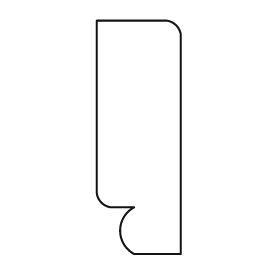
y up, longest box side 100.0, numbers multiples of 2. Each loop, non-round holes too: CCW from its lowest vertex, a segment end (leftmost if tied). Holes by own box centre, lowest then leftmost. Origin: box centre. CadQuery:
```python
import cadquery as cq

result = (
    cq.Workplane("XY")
    .moveTo(-2.0, -50.0)
    .lineTo(18.0, -50.0)
    .lineTo(18.0, 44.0)
    .threePointArc((16.0, 48.0), (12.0, 50.0))
    .lineTo(-18.0, 50.0)
    .lineTo(-18.0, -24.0)
    .threePointArc((-16.0, -28.0), (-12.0, -30.0))
    .lineTo(-2.0, -30.0)
    .threePointArc((-8.0, -40.0), (-2.0, -50.0))
    .close()
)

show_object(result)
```